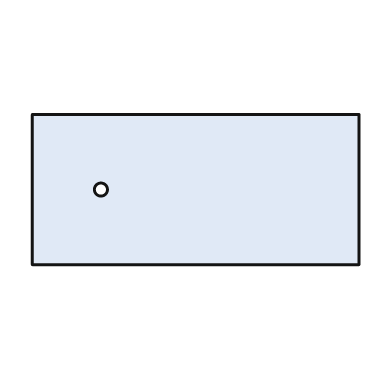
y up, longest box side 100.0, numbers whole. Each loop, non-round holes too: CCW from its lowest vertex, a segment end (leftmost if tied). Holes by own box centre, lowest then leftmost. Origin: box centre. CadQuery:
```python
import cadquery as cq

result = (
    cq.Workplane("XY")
    .moveTo(-50.0, -23.0)
    .lineTo(50.0, -23.0)
    .lineTo(50.0, 23.0)
    .lineTo(-50.0, 23.0)
    .close()
    .moveTo(-29.0, 0.0)
    .circle(2.0)
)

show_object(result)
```